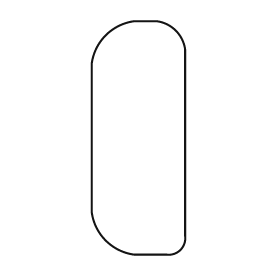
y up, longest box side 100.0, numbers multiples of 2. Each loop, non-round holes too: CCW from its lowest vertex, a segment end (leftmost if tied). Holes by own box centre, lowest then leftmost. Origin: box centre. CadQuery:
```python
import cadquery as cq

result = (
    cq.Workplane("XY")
    .moveTo(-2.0, -50.0)
    .lineTo(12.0, -50.0)
    .threePointArc((18.0, -48.0), (20.0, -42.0))
    .lineTo(20.0, 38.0)
    .threePointArc((16.0, 46.0), (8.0, 50.0))
    .lineTo(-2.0, 50.0)
    .threePointArc((-14.0, 44.0), (-20.0, 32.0))
    .lineTo(-20.0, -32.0)
    .threePointArc((-14.0, -44.0), (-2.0, -50.0))
    .close()
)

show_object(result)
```